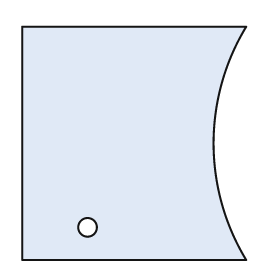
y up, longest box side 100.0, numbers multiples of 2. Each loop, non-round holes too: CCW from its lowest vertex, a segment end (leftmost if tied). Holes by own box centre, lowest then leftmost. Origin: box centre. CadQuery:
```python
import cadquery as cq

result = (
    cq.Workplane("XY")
    .moveTo(-48.0, -50.0)
    .lineTo(48.0, -50.0)
    .threePointArc((34.0, 0.0), (48.0, 50.0))
    .lineTo(-48.0, 50.0)
    .close()
    .moveTo(-20.0, -36.0)
    .circle(4.0)
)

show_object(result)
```